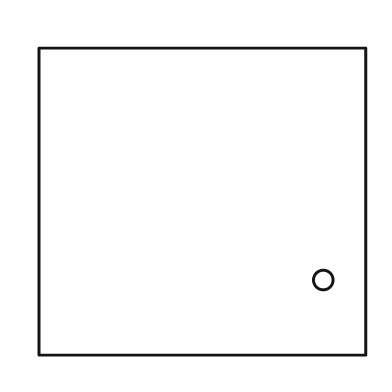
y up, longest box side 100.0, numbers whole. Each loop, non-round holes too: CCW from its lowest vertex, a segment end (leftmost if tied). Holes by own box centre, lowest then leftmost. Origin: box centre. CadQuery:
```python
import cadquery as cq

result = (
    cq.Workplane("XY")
    .moveTo(-50.0, -47.0)
    .lineTo(50.0, -47.0)
    .lineTo(50.0, 47.0)
    .lineTo(-50.0, 47.0)
    .close()
    .moveTo(37.0, -24.0)
    .circle(3.0)
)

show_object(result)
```